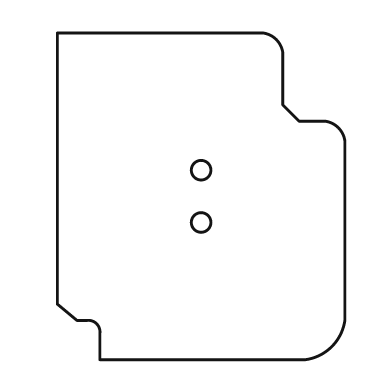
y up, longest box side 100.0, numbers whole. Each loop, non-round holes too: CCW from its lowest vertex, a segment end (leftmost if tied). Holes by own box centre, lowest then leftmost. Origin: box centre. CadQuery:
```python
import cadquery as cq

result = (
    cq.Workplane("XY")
    .moveTo(-31.0, -50.0)
    .lineTo(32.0, -50.0)
    .threePointArc((40.0, -46.0), (44.0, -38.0))
    .lineTo(44.0, 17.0)
    .threePointArc((42.0, 21.0), (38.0, 23.0))
    .lineTo(30.0, 23.0)
    .lineTo(25.0, 28.0)
    .lineTo(25.0, 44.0)
    .threePointArc((23.0, 48.0), (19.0, 50.0))
    .lineTo(-44.0, 50.0)
    .lineTo(-44.0, -33.0)
    .lineTo(-38.0, -38.0)
    .lineTo(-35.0, -38.0)
    .threePointArc((-32.0, -39.0), (-31.0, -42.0))
    .close()
    .moveTo(0.0, -8.0)
    .circle(3.0)
    .moveTo(0.0, 8.0)
    .circle(3.0)
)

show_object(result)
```